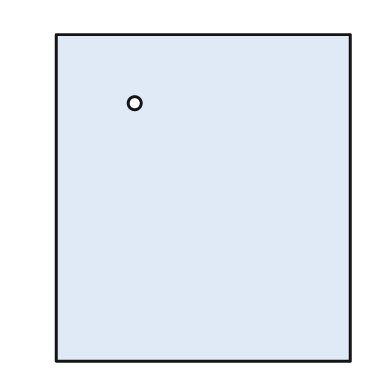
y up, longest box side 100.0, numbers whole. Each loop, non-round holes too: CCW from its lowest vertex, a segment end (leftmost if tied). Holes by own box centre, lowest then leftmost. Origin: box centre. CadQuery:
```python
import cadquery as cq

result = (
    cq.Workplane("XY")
    .moveTo(-45.0, -50.0)
    .lineTo(45.0, -50.0)
    .lineTo(45.0, 50.0)
    .lineTo(-45.0, 50.0)
    .close()
    .moveTo(-21.0, 29.0)
    .circle(2.0)
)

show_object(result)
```